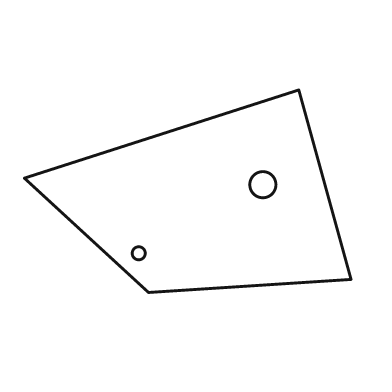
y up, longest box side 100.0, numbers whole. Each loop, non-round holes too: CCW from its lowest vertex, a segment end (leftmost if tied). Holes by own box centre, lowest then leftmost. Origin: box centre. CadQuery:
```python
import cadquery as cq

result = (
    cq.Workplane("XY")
    .moveTo(-12.0, -31.0)
    .lineTo(50.0, -27.0)
    .lineTo(34.0, 31.0)
    .lineTo(-50.0, 4.0)
    .close()
    .moveTo(-15.0, -19.0)
    .circle(2.0)
    .moveTo(23.0, 2.0)
    .circle(4.0)
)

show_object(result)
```